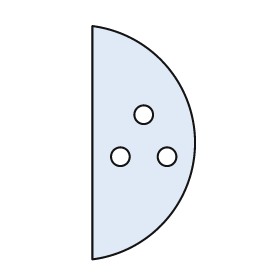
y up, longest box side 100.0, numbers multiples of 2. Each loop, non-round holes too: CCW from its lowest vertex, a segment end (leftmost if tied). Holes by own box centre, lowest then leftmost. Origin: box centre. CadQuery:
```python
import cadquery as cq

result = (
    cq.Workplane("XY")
    .moveTo(-22.0, -50.0)
    .threePointArc((22.0, 0.0), (-22.0, 50.0))
    .close()
    .moveTo(-10.0, -6.0)
    .circle(4.0)
    .moveTo(10.0, -6.0)
    .circle(4.0)
    .moveTo(0.0, 12.0)
    .circle(4.0)
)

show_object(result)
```